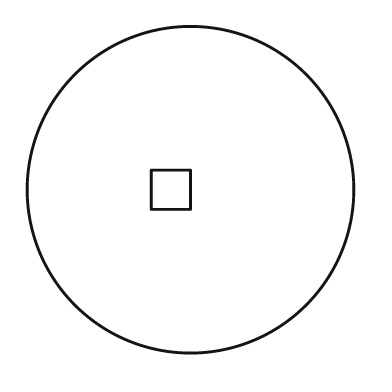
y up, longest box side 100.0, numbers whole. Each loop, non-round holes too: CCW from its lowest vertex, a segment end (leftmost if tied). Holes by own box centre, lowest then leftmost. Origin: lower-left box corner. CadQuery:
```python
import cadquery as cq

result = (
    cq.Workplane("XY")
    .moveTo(50.0, 50.0)
    .circle(50.0)
    .moveTo(38.0, 44.0)
    .lineTo(50.0, 44.0)
    .lineTo(50.0, 56.0)
    .lineTo(38.0, 56.0)
    .close()
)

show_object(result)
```